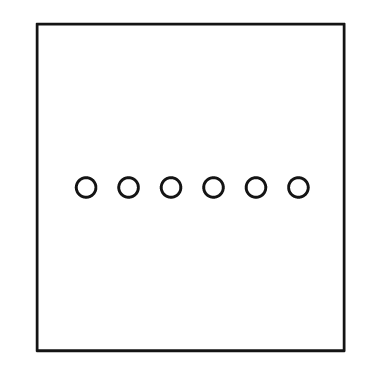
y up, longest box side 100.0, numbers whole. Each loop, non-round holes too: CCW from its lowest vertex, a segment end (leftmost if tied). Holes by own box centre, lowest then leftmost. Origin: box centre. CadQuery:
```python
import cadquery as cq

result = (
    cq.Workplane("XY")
    .moveTo(-47.0, -50.0)
    .lineTo(47.0, -50.0)
    .lineTo(47.0, 50.0)
    .lineTo(-47.0, 50.0)
    .close()
    .moveTo(-32.0, 0.0)
    .circle(3.0)
    .moveTo(-19.0, 0.0)
    .circle(3.0)
    .moveTo(-6.0, 0.0)
    .circle(3.0)
    .moveTo(7.0, 0.0)
    .circle(3.0)
    .moveTo(20.0, 0.0)
    .circle(3.0)
    .moveTo(33.0, 0.0)
    .circle(3.0)
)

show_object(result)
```